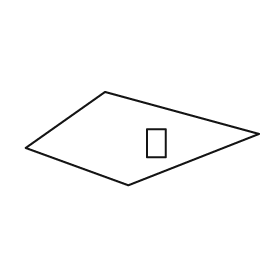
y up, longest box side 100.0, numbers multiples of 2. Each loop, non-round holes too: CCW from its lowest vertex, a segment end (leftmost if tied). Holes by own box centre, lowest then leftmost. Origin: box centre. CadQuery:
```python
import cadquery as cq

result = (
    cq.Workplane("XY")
    .moveTo(-6.0, -20.0)
    .lineTo(50.0, 2.0)
    .lineTo(-16.0, 20.0)
    .lineTo(-50.0, -4.0)
    .close()
    .moveTo(2.0, -8.0)
    .lineTo(10.0, -8.0)
    .lineTo(10.0, 4.0)
    .lineTo(2.0, 4.0)
    .close()
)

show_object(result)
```